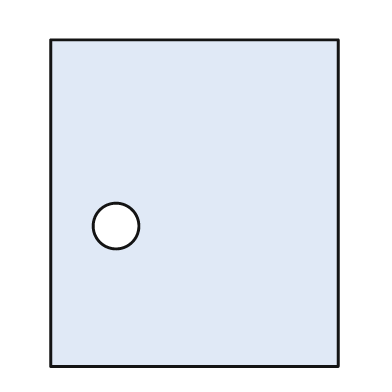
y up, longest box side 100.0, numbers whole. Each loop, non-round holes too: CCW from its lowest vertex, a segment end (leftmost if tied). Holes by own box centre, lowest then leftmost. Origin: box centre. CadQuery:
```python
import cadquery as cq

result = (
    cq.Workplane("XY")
    .moveTo(-44.0, -50.0)
    .lineTo(44.0, -50.0)
    .lineTo(44.0, 50.0)
    .lineTo(-44.0, 50.0)
    .close()
    .moveTo(-24.0, -7.0)
    .circle(7.0)
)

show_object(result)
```